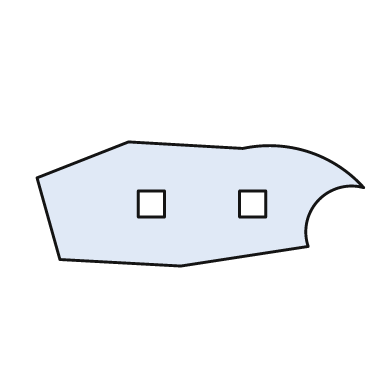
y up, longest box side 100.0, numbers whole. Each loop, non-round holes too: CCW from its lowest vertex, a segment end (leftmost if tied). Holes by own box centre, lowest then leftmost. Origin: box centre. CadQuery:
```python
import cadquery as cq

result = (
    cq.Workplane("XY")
    .moveTo(-6.0, -19.0)
    .lineTo(33.0, -13.0)
    .threePointArc((36.0, 1.0), (50.0, 5.0))
    .threePointArc((33.0, 16.0), (13.0, 17.0))
    .lineTo(-22.0, 19.0)
    .lineTo(-50.0, 8.0)
    .lineTo(-43.0, -17.0)
    .close()
    .moveTo(-19.0, -4.0)
    .lineTo(-11.0, -4.0)
    .lineTo(-11.0, 4.0)
    .lineTo(-19.0, 4.0)
    .close()
    .moveTo(12.0, -4.0)
    .lineTo(20.0, -4.0)
    .lineTo(20.0, 4.0)
    .lineTo(12.0, 4.0)
    .close()
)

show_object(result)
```